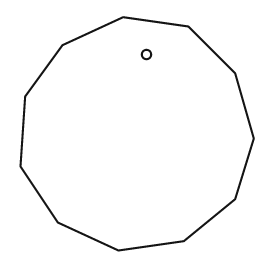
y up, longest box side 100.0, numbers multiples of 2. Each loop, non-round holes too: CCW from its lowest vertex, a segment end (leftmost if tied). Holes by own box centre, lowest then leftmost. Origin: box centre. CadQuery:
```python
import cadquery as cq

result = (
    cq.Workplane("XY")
    .moveTo(-8.0, -50.0)
    .lineTo(20.0, -46.0)
    .lineTo(42.0, -28.0)
    .lineTo(50.0, -2.0)
    .lineTo(42.0, 26.0)
    .lineTo(22.0, 46.0)
    .lineTo(-6.0, 50.0)
    .lineTo(-32.0, 38.0)
    .lineTo(-48.0, 16.0)
    .lineTo(-50.0, -14.0)
    .lineTo(-34.0, -38.0)
    .close()
    .moveTo(4.0, 34.0)
    .circle(2.0)
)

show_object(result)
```